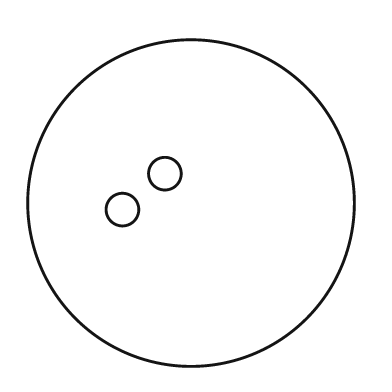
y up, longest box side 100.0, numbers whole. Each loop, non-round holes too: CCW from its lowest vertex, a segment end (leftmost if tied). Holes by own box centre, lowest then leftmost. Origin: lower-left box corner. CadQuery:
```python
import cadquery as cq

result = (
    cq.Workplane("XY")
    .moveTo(50.0, 50.0)
    .circle(50.0)
    .moveTo(29.0, 48.0)
    .circle(5.0)
    .moveTo(42.0, 59.0)
    .circle(5.0)
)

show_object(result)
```